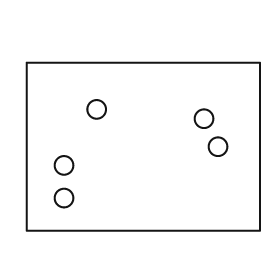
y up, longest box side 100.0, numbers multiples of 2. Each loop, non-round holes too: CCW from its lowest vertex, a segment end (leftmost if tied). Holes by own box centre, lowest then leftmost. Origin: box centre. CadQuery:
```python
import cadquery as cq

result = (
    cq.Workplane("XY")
    .moveTo(-50.0, -36.0)
    .lineTo(50.0, -36.0)
    .lineTo(50.0, 36.0)
    .lineTo(-50.0, 36.0)
    .close()
    .moveTo(-34.0, -22.0)
    .circle(4.0)
    .moveTo(-34.0, -8.0)
    .circle(4.0)
    .moveTo(32.0, 0.0)
    .circle(4.0)
    .moveTo(26.0, 12.0)
    .circle(4.0)
    .moveTo(-20.0, 16.0)
    .circle(4.0)
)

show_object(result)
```